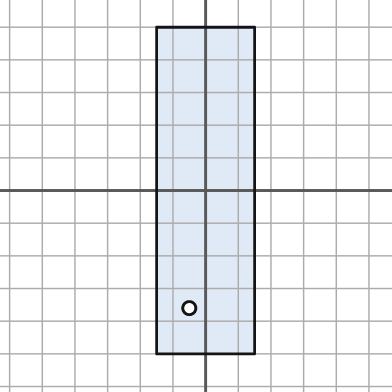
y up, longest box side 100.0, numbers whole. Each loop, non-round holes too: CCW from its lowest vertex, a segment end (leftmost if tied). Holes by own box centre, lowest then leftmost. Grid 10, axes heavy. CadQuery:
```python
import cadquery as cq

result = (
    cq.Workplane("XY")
    .moveTo(-15.0, -50.0)
    .lineTo(15.0, -50.0)
    .lineTo(15.0, 50.0)
    .lineTo(-15.0, 50.0)
    .close()
    .moveTo(-5.0, -36.0)
    .circle(2.0)
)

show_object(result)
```